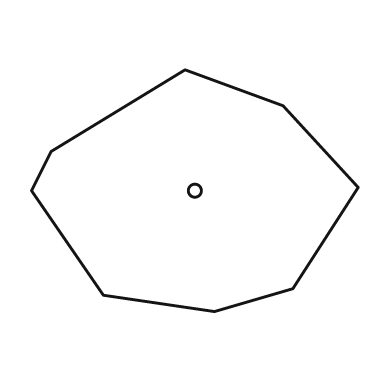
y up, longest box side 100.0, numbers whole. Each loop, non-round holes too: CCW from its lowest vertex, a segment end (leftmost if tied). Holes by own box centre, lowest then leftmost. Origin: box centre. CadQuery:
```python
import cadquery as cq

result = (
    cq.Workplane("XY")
    .moveTo(6.0, -37.0)
    .lineTo(30.0, -30.0)
    .lineTo(50.0, 1.0)
    .lineTo(27.0, 26.0)
    .lineTo(-3.0, 37.0)
    .lineTo(-44.0, 12.0)
    .lineTo(-50.0, 0.0)
    .lineTo(-28.0, -32.0)
    .close()
    .moveTo(0.0, 0.0)
    .circle(2.0)
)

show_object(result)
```